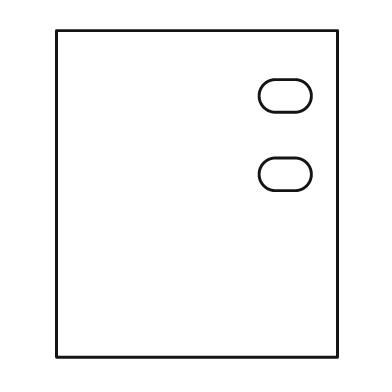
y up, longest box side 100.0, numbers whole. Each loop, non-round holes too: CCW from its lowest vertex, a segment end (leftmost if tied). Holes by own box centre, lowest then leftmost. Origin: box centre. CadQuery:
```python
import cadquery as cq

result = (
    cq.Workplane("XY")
    .moveTo(-43.0, -50.0)
    .lineTo(43.0, -50.0)
    .lineTo(43.0, 50.0)
    .lineTo(-43.0, 50.0)
    .close()
    .moveTo(24.0, 1.0)
    .lineTo(30.0, 1.0)
    .threePointArc((35.0, 6.0), (30.0, 11.0))
    .lineTo(24.0, 11.0)
    .threePointArc((19.0, 6.0), (24.0, 1.0))
    .close()
    .moveTo(24.0, 25.0)
    .lineTo(30.0, 25.0)
    .threePointArc((35.0, 30.0), (30.0, 35.0))
    .lineTo(24.0, 35.0)
    .threePointArc((19.0, 30.0), (24.0, 25.0))
    .close()
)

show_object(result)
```